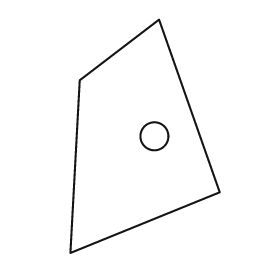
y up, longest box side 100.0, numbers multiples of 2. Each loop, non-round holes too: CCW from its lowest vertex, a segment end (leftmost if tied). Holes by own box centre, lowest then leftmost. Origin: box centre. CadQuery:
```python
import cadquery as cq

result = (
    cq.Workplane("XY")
    .moveTo(-32.0, -50.0)
    .lineTo(32.0, -24.0)
    .lineTo(6.0, 50.0)
    .lineTo(-28.0, 24.0)
    .close()
    .moveTo(4.0, 0.0)
    .circle(6.0)
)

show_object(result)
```